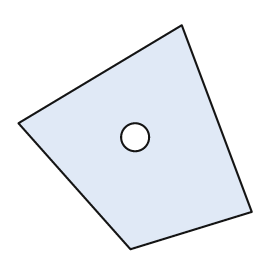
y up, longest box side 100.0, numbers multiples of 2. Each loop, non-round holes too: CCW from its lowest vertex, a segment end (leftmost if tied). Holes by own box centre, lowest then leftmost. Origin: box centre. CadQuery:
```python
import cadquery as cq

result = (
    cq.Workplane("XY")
    .moveTo(-2.0, -48.0)
    .lineTo(50.0, -32.0)
    .lineTo(20.0, 48.0)
    .lineTo(-50.0, 6.0)
    .close()
    .moveTo(0.0, 0.0)
    .circle(6.0)
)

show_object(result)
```